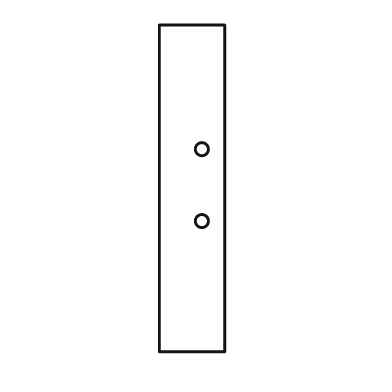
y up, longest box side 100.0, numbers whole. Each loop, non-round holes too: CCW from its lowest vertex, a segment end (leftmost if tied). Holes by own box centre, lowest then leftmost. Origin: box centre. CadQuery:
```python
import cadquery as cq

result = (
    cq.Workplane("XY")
    .moveTo(-10.0, -50.0)
    .lineTo(10.0, -50.0)
    .lineTo(10.0, 50.0)
    .lineTo(-10.0, 50.0)
    .close()
    .moveTo(3.0, -10.0)
    .circle(2.0)
    .moveTo(3.0, 12.0)
    .circle(2.0)
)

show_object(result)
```